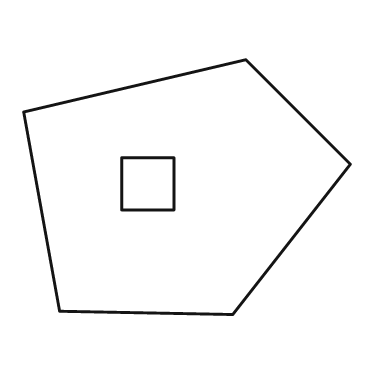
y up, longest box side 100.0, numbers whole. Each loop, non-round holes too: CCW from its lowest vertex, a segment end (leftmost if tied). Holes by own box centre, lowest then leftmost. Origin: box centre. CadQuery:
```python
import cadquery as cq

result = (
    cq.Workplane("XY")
    .moveTo(14.0, -39.0)
    .lineTo(50.0, 7.0)
    .lineTo(18.0, 39.0)
    .lineTo(-50.0, 23.0)
    .lineTo(-39.0, -38.0)
    .close()
    .moveTo(-20.0, -7.0)
    .lineTo(-4.0, -7.0)
    .lineTo(-4.0, 9.0)
    .lineTo(-20.0, 9.0)
    .close()
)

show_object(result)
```